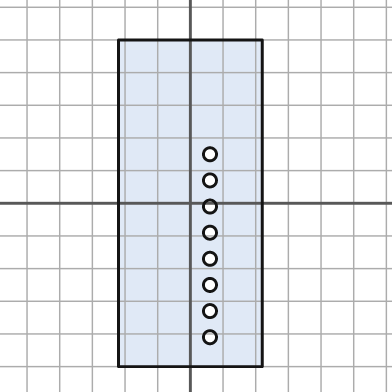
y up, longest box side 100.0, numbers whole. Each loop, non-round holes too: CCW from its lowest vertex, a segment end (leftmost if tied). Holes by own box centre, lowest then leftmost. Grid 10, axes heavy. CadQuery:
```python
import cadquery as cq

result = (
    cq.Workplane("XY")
    .moveTo(-22.0, -50.0)
    .lineTo(22.0, -50.0)
    .lineTo(22.0, 50.0)
    .lineTo(-22.0, 50.0)
    .close()
    .moveTo(6.0, -41.0)
    .circle(2.0)
    .moveTo(6.0, -33.0)
    .circle(2.0)
    .moveTo(6.0, -25.0)
    .circle(2.0)
    .moveTo(6.0, -17.0)
    .circle(2.0)
    .moveTo(6.0, -9.0)
    .circle(2.0)
    .moveTo(6.0, -1.0)
    .circle(2.0)
    .moveTo(6.0, 7.0)
    .circle(2.0)
    .moveTo(6.0, 15.0)
    .circle(2.0)
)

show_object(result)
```